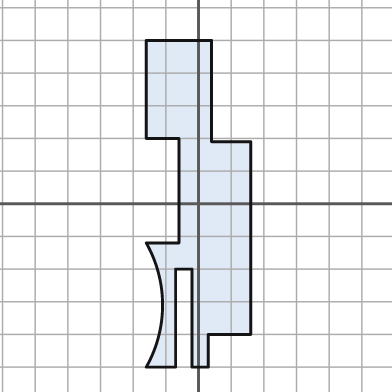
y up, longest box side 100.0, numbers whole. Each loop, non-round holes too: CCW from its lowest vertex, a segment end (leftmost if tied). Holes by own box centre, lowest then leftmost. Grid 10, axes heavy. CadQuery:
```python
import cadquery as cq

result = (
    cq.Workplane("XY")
    .moveTo(-16.0, -50.0)
    .lineTo(-7.0, -50.0)
    .lineTo(-7.0, -20.0)
    .lineTo(-2.0, -20.0)
    .lineTo(-2.0, -50.0)
    .lineTo(3.0, -50.0)
    .lineTo(3.0, -40.0)
    .lineTo(16.0, -40.0)
    .lineTo(16.0, 19.0)
    .lineTo(4.0, 19.0)
    .lineTo(4.0, 50.0)
    .lineTo(-16.0, 50.0)
    .lineTo(-16.0, 20.0)
    .lineTo(-6.0, 20.0)
    .lineTo(-6.0, -12.0)
    .lineTo(-16.0, -12.0)
    .threePointArc((-11.0, -31.0), (-16.0, -50.0))
    .close()
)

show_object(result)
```